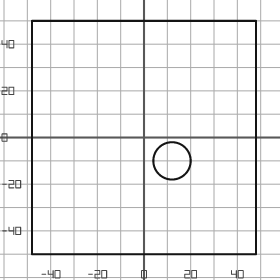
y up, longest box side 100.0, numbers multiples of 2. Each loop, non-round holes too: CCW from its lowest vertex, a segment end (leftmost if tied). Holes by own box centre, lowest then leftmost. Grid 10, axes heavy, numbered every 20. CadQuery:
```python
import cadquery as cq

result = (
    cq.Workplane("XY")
    .moveTo(-48.0, -50.0)
    .lineTo(48.0, -50.0)
    .lineTo(48.0, 50.0)
    .lineTo(-48.0, 50.0)
    .close()
    .moveTo(12.0, -10.0)
    .circle(8.0)
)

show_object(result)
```